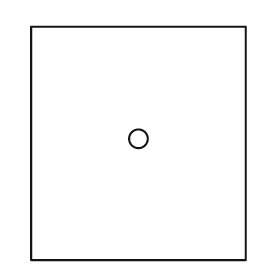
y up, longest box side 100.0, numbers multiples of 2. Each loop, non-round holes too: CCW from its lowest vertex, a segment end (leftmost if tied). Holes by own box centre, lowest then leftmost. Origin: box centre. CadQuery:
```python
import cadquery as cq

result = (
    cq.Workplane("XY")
    .moveTo(-46.0, -50.0)
    .lineTo(46.0, -50.0)
    .lineTo(46.0, 50.0)
    .lineTo(-46.0, 50.0)
    .close()
    .moveTo(0.0, 2.0)
    .circle(4.0)
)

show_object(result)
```